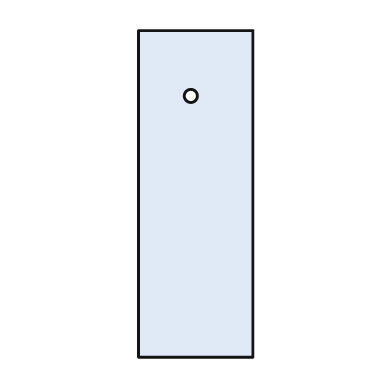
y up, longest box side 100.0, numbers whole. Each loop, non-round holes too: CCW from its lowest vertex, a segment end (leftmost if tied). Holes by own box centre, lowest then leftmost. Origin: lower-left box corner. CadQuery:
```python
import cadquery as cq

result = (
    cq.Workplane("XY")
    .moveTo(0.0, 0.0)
    .lineTo(35.0, 0.0)
    .lineTo(35.0, 100.0)
    .lineTo(0.0, 100.0)
    .close()
    .moveTo(16.0, 80.0)
    .circle(2.0)
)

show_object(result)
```